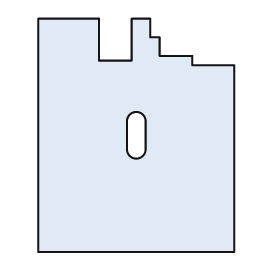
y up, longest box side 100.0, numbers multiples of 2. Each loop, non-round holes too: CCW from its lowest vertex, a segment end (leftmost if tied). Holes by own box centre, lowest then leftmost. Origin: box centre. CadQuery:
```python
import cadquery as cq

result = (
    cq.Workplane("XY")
    .moveTo(-42.0, -50.0)
    .lineTo(42.0, -50.0)
    .lineTo(42.0, 30.0)
    .lineTo(24.0, 30.0)
    .lineTo(24.0, 34.0)
    .lineTo(10.0, 34.0)
    .lineTo(10.0, 42.0)
    .lineTo(6.0, 42.0)
    .lineTo(6.0, 50.0)
    .lineTo(-2.0, 50.0)
    .lineTo(-2.0, 32.0)
    .lineTo(-16.0, 32.0)
    .lineTo(-16.0, 50.0)
    .lineTo(-42.0, 50.0)
    .close()
    .moveTo(-4.0, -6.0)
    .threePointArc((0.0, -10.0), (4.0, -6.0))
    .lineTo(4.0, 6.0)
    .threePointArc((0.0, 10.0), (-4.0, 6.0))
    .close()
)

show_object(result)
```